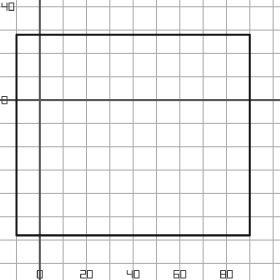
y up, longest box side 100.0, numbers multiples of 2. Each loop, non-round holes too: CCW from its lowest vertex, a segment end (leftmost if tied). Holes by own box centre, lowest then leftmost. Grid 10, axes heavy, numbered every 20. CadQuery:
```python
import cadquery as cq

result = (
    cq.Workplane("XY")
    .moveTo(-10.0, -58.0)
    .lineTo(90.0, -58.0)
    .lineTo(90.0, 28.0)
    .lineTo(-10.0, 28.0)
    .close()
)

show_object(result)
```